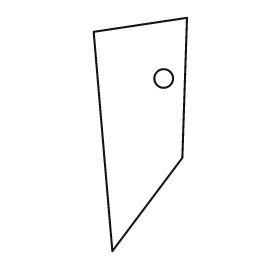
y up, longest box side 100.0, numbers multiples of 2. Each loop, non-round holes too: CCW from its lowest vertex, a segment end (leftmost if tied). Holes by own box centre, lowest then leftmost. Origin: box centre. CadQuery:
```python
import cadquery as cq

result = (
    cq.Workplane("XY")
    .moveTo(-12.0, -50.0)
    .lineTo(18.0, -10.0)
    .lineTo(20.0, 50.0)
    .lineTo(-20.0, 44.0)
    .close()
    .moveTo(10.0, 24.0)
    .circle(4.0)
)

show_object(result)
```